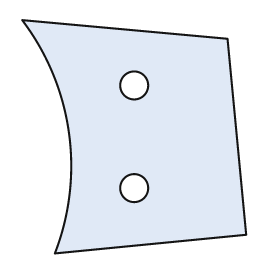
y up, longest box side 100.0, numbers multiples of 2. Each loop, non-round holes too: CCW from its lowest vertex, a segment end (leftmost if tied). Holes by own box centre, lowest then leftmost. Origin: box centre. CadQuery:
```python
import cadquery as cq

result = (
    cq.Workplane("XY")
    .moveTo(-34.0, -50.0)
    .lineTo(48.0, -42.0)
    .lineTo(40.0, 42.0)
    .lineTo(-48.0, 50.0)
    .threePointArc((-28.0, 2.0), (-34.0, -50.0))
    .close()
    .moveTo(0.0, -22.0)
    .circle(6.0)
    .moveTo(0.0, 22.0)
    .circle(6.0)
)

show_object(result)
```